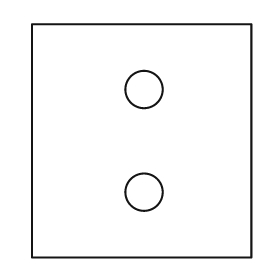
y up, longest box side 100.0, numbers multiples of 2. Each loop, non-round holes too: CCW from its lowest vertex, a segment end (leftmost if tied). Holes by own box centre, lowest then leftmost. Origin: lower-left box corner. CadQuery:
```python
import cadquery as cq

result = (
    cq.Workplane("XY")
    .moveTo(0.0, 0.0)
    .lineTo(94.0, 0.0)
    .lineTo(94.0, 100.0)
    .lineTo(0.0, 100.0)
    .close()
    .moveTo(48.0, 28.0)
    .circle(8.0)
    .moveTo(48.0, 72.0)
    .circle(8.0)
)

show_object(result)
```